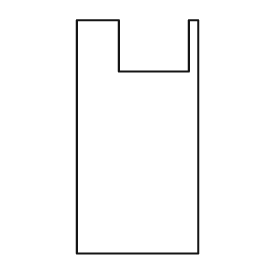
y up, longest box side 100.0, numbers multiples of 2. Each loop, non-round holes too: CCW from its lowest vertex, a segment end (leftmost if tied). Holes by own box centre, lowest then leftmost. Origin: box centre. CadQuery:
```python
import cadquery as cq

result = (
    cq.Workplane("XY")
    .moveTo(-26.0, -50.0)
    .lineTo(26.0, -50.0)
    .lineTo(26.0, 50.0)
    .lineTo(22.0, 50.0)
    .lineTo(22.0, 28.0)
    .lineTo(-8.0, 28.0)
    .lineTo(-8.0, 50.0)
    .lineTo(-26.0, 50.0)
    .close()
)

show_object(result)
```